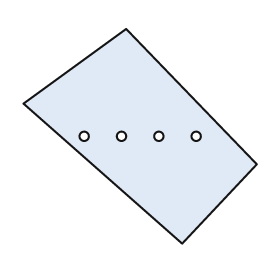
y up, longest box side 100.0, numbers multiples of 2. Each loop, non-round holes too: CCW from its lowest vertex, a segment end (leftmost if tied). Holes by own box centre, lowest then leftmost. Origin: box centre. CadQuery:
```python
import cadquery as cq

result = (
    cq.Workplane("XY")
    .moveTo(18.0, -46.0)
    .lineTo(50.0, -12.0)
    .lineTo(-6.0, 46.0)
    .lineTo(-50.0, 14.0)
    .close()
    .moveTo(-24.0, 0.0)
    .circle(2.0)
    .moveTo(-8.0, 0.0)
    .circle(2.0)
    .moveTo(8.0, 0.0)
    .circle(2.0)
    .moveTo(24.0, 0.0)
    .circle(2.0)
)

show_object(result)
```